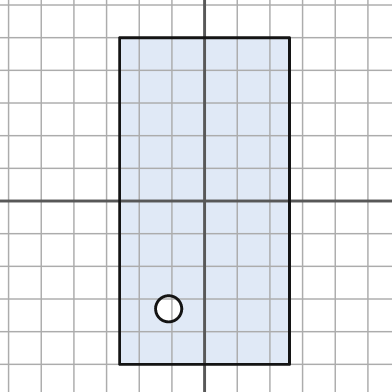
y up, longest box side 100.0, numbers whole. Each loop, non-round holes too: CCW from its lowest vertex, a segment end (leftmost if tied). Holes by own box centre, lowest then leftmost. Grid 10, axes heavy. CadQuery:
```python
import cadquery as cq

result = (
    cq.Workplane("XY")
    .moveTo(-26.0, -50.0)
    .lineTo(26.0, -50.0)
    .lineTo(26.0, 50.0)
    .lineTo(-26.0, 50.0)
    .close()
    .moveTo(-11.0, -33.0)
    .circle(4.0)
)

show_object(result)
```